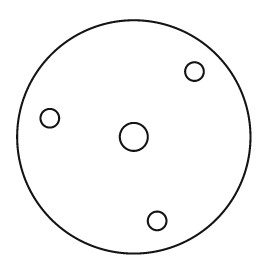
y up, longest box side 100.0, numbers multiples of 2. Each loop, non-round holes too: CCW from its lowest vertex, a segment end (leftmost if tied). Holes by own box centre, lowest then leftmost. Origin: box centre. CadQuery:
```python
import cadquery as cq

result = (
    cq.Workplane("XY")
    .moveTo(0.0, 0.0)
    .circle(50.0)
    .moveTo(10.0, -36.0)
    .circle(4.0)
    .moveTo(0.0, 0.0)
    .circle(6.0)
    .moveTo(-36.0, 8.0)
    .circle(4.0)
    .moveTo(26.0, 28.0)
    .circle(4.0)
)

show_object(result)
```